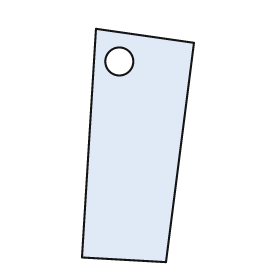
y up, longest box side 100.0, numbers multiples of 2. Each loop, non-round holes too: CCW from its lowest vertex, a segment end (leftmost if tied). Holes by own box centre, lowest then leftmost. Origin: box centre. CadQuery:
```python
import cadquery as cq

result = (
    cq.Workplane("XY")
    .moveTo(12.0, -50.0)
    .lineTo(24.0, 44.0)
    .lineTo(-18.0, 50.0)
    .lineTo(-24.0, -48.0)
    .close()
    .moveTo(-8.0, 36.0)
    .circle(6.0)
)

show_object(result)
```